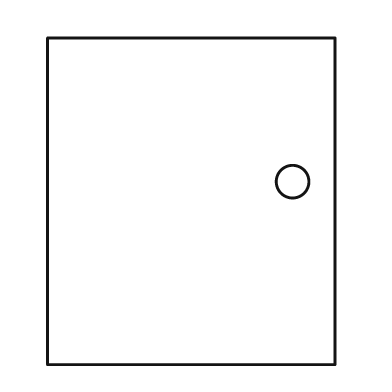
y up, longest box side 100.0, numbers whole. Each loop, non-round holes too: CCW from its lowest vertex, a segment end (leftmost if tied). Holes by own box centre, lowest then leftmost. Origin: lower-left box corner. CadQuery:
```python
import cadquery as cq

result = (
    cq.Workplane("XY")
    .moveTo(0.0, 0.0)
    .lineTo(88.0, 0.0)
    .lineTo(88.0, 100.0)
    .lineTo(0.0, 100.0)
    .close()
    .moveTo(75.0, 56.0)
    .circle(5.0)
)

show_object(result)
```